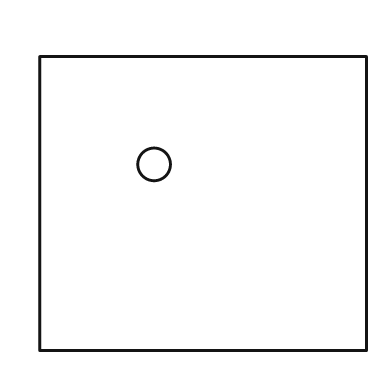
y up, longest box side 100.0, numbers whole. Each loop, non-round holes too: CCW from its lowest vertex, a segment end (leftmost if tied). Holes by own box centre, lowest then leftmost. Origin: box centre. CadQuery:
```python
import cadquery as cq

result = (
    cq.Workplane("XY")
    .moveTo(-50.0, -45.0)
    .lineTo(50.0, -45.0)
    .lineTo(50.0, 45.0)
    .lineTo(-50.0, 45.0)
    .close()
    .moveTo(-15.0, 12.0)
    .circle(5.0)
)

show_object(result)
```